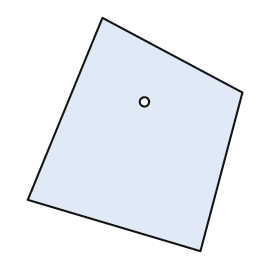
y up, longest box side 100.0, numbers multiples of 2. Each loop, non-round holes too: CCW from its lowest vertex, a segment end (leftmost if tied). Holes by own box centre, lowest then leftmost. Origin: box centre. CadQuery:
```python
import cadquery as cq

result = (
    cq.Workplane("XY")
    .moveTo(28.0, -50.0)
    .lineTo(46.0, 18.0)
    .lineTo(-14.0, 50.0)
    .lineTo(-46.0, -28.0)
    .close()
    .moveTo(4.0, 14.0)
    .circle(2.0)
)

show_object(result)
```